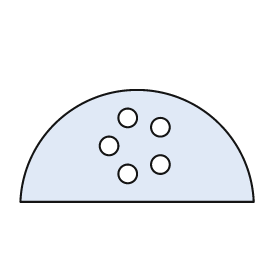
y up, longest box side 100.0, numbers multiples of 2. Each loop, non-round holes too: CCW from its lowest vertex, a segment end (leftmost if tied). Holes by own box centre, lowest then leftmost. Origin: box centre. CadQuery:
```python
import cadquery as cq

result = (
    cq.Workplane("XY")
    .moveTo(-50.0, -24.0)
    .lineTo(50.0, -24.0)
    .threePointArc((0.0, 24.0), (-50.0, -24.0))
    .close()
    .moveTo(-4.0, -12.0)
    .circle(4.0)
    .moveTo(10.0, -8.0)
    .circle(4.0)
    .moveTo(-12.0, 0.0)
    .circle(4.0)
    .moveTo(10.0, 8.0)
    .circle(4.0)
    .moveTo(-4.0, 12.0)
    .circle(4.0)
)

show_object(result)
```